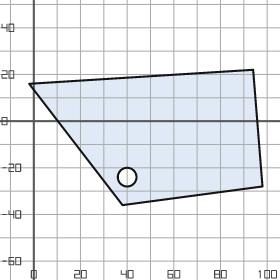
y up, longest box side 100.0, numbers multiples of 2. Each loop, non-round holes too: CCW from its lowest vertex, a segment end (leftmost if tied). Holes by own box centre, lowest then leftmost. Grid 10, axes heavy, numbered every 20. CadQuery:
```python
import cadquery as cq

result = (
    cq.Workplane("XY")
    .moveTo(38.0, -36.0)
    .lineTo(98.0, -28.0)
    .lineTo(94.0, 22.0)
    .lineTo(-2.0, 16.0)
    .close()
    .moveTo(40.0, -24.0)
    .circle(4.0)
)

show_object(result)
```